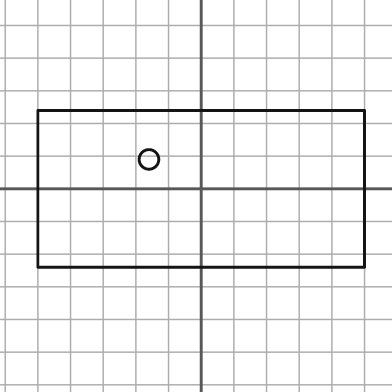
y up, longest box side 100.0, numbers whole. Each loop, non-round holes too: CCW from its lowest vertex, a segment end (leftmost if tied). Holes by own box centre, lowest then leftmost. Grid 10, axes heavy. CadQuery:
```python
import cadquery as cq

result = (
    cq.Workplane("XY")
    .moveTo(-50.0, -24.0)
    .lineTo(50.0, -24.0)
    .lineTo(50.0, 24.0)
    .lineTo(-50.0, 24.0)
    .close()
    .moveTo(-16.0, 9.0)
    .circle(3.0)
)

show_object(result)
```